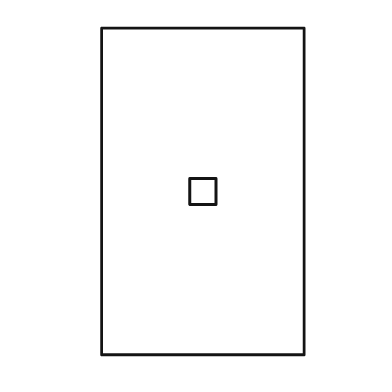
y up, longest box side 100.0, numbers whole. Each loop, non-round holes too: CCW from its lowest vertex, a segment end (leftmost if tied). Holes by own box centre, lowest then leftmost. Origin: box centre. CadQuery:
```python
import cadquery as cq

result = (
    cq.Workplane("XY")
    .moveTo(-31.0, -50.0)
    .lineTo(31.0, -50.0)
    .lineTo(31.0, 50.0)
    .lineTo(-31.0, 50.0)
    .close()
    .moveTo(-4.0, -4.0)
    .lineTo(4.0, -4.0)
    .lineTo(4.0, 4.0)
    .lineTo(-4.0, 4.0)
    .close()
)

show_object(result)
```